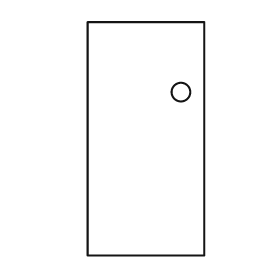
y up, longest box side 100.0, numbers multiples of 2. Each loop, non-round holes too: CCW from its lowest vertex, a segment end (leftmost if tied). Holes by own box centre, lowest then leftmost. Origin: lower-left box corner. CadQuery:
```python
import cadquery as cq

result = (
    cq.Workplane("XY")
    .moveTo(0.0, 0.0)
    .lineTo(50.0, 0.0)
    .lineTo(50.0, 100.0)
    .lineTo(0.0, 100.0)
    .close()
    .moveTo(40.0, 70.0)
    .circle(4.0)
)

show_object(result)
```